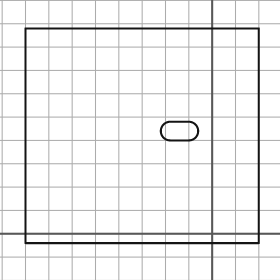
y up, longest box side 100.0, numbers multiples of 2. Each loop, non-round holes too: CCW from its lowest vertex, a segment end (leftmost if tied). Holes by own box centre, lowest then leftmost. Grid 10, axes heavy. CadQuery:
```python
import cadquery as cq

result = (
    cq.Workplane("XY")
    .moveTo(-80.0, -4.0)
    .lineTo(20.0, -4.0)
    .lineTo(20.0, 88.0)
    .lineTo(-80.0, 88.0)
    .close()
    .moveTo(-18.0, 40.0)
    .lineTo(-10.0, 40.0)
    .threePointArc((-6.0, 44.0), (-10.0, 48.0))
    .lineTo(-18.0, 48.0)
    .threePointArc((-22.0, 44.0), (-18.0, 40.0))
    .close()
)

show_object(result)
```